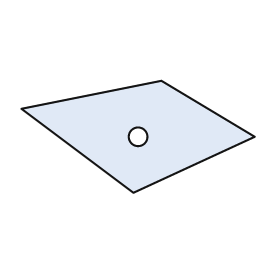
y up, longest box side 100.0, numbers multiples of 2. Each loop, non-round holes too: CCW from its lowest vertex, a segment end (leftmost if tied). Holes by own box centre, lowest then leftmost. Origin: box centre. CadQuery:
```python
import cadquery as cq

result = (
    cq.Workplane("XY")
    .moveTo(-2.0, -24.0)
    .lineTo(50.0, 0.0)
    .lineTo(10.0, 24.0)
    .lineTo(-50.0, 12.0)
    .close()
    .moveTo(0.0, 0.0)
    .circle(4.0)
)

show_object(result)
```